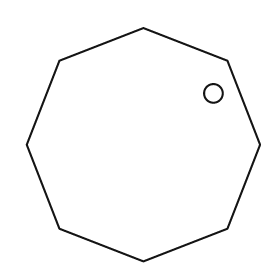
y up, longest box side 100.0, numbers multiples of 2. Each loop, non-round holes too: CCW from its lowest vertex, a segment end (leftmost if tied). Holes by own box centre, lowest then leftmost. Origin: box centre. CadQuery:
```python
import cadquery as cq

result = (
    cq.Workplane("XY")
    .moveTo(0.0, -50.0)
    .lineTo(36.0, -36.0)
    .lineTo(50.0, 0.0)
    .lineTo(36.0, 36.0)
    .lineTo(0.0, 50.0)
    .lineTo(-36.0, 36.0)
    .lineTo(-50.0, 0.0)
    .lineTo(-36.0, -36.0)
    .close()
    .moveTo(30.0, 22.0)
    .circle(4.0)
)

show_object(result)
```